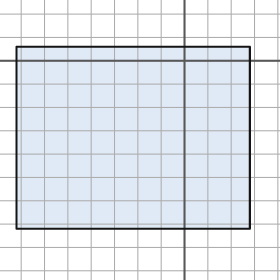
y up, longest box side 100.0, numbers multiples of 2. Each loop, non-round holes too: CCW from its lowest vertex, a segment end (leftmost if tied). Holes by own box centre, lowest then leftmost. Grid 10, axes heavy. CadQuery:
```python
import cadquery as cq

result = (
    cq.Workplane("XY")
    .moveTo(-72.0, -72.0)
    .lineTo(28.0, -72.0)
    .lineTo(28.0, 6.0)
    .lineTo(-72.0, 6.0)
    .close()
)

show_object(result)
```